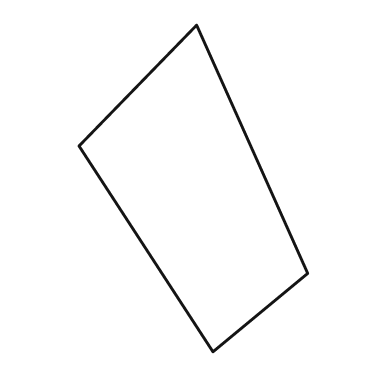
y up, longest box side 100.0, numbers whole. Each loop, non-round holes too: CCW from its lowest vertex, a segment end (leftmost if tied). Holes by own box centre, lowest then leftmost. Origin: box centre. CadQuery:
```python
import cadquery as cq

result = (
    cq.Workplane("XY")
    .moveTo(6.0, -50.0)
    .lineTo(35.0, -26.0)
    .lineTo(1.0, 50.0)
    .lineTo(-35.0, 13.0)
    .close()
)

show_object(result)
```